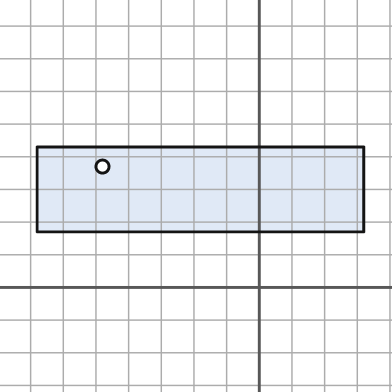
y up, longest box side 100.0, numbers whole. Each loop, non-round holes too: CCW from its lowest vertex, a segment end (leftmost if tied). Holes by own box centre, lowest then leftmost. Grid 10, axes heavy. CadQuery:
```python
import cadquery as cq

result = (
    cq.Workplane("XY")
    .moveTo(-68.0, 17.0)
    .lineTo(32.0, 17.0)
    .lineTo(32.0, 43.0)
    .lineTo(-68.0, 43.0)
    .close()
    .moveTo(-48.0, 37.0)
    .circle(2.0)
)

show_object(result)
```